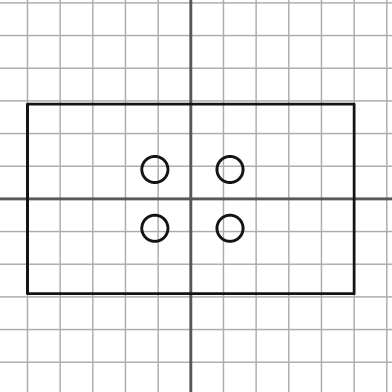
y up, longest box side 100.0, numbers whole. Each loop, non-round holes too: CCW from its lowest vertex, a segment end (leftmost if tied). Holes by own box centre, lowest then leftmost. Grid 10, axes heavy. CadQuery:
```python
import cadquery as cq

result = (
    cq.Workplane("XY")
    .moveTo(-50.0, -29.0)
    .lineTo(50.0, -29.0)
    .lineTo(50.0, 29.0)
    .lineTo(-50.0, 29.0)
    .close()
    .moveTo(-11.0, -9.0)
    .circle(4.0)
    .moveTo(12.0, -9.0)
    .circle(4.0)
    .moveTo(-11.0, 9.0)
    .circle(4.0)
    .moveTo(12.0, 9.0)
    .circle(4.0)
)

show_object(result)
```